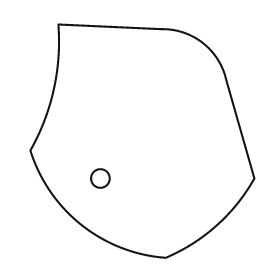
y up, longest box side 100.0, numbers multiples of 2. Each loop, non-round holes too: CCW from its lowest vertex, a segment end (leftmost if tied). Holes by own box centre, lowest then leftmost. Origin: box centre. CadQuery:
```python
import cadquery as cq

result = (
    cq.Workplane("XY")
    .moveTo(10.0, -50.0)
    .threePointArc((32.0, -36.0), (48.0, -16.0))
    .lineTo(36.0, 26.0)
    .threePointArc((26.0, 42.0), (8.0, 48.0))
    .lineTo(-36.0, 50.0)
    .threePointArc((-38.0, 22.0), (-48.0, -4.0))
    .threePointArc((-26.0, -36.0), (10.0, -50.0))
    .close()
    .moveTo(-18.0, -16.0)
    .circle(4.0)
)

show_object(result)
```